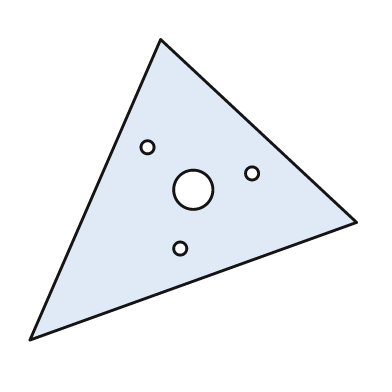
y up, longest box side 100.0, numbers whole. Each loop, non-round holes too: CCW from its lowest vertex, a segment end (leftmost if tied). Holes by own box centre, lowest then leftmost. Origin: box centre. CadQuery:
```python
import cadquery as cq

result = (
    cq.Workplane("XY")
    .moveTo(-50.0, -46.0)
    .lineTo(50.0, -10.0)
    .lineTo(-10.0, 46.0)
    .close()
    .moveTo(-4.0, -18.0)
    .circle(2.0)
    .moveTo(0.0, 0.0)
    .circle(6.0)
    .moveTo(18.0, 5.0)
    .circle(2.0)
    .moveTo(-14.0, 13.0)
    .circle(2.0)
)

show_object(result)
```